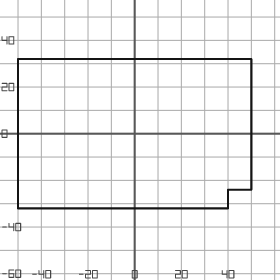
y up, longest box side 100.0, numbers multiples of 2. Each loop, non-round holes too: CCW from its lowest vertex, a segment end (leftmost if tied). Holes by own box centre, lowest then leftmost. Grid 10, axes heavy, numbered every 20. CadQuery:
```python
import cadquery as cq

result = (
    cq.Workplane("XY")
    .moveTo(-50.0, -32.0)
    .lineTo(40.0, -32.0)
    .lineTo(40.0, -24.0)
    .lineTo(50.0, -24.0)
    .lineTo(50.0, 32.0)
    .lineTo(-50.0, 32.0)
    .close()
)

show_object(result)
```